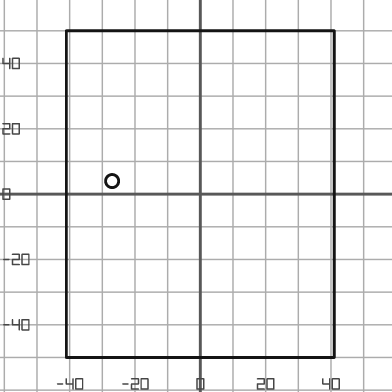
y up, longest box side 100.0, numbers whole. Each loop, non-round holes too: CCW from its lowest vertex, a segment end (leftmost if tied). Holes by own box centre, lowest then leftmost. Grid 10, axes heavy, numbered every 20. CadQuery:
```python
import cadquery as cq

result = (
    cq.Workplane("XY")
    .moveTo(-41.0, -50.0)
    .lineTo(41.0, -50.0)
    .lineTo(41.0, 50.0)
    .lineTo(-41.0, 50.0)
    .close()
    .moveTo(-27.0, 4.0)
    .circle(2.0)
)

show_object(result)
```